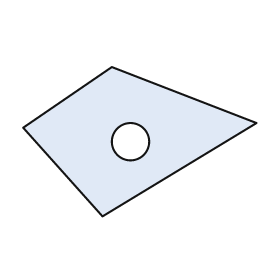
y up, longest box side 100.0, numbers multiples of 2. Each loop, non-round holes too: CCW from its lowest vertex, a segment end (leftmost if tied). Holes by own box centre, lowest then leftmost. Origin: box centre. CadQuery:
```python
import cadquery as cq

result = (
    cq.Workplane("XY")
    .moveTo(-16.0, -32.0)
    .lineTo(50.0, 8.0)
    .lineTo(-12.0, 32.0)
    .lineTo(-50.0, 6.0)
    .close()
    .moveTo(-4.0, 0.0)
    .circle(8.0)
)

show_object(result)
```